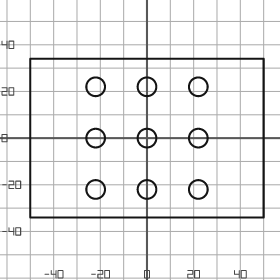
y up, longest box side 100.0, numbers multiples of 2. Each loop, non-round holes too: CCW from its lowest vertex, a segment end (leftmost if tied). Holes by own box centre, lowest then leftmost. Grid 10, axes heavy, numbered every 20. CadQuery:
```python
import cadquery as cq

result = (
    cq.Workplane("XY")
    .moveTo(-50.0, -34.0)
    .lineTo(50.0, -34.0)
    .lineTo(50.0, 34.0)
    .lineTo(-50.0, 34.0)
    .close()
    .moveTo(-22.0, -22.0)
    .circle(4.0)
    .moveTo(0.0, -22.0)
    .circle(4.0)
    .moveTo(22.0, -22.0)
    .circle(4.0)
    .moveTo(-22.0, 0.0)
    .circle(4.0)
    .moveTo(0.0, 0.0)
    .circle(4.0)
    .moveTo(22.0, 0.0)
    .circle(4.0)
    .moveTo(-22.0, 22.0)
    .circle(4.0)
    .moveTo(0.0, 22.0)
    .circle(4.0)
    .moveTo(22.0, 22.0)
    .circle(4.0)
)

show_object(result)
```